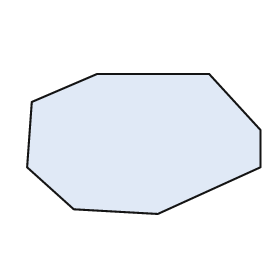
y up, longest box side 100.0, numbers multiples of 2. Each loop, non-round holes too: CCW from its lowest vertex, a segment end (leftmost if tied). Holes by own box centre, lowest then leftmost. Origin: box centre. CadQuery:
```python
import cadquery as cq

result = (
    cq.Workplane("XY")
    .moveTo(6.0, -30.0)
    .lineTo(50.0, -10.0)
    .lineTo(50.0, 6.0)
    .lineTo(28.0, 30.0)
    .lineTo(-20.0, 30.0)
    .lineTo(-48.0, 18.0)
    .lineTo(-50.0, -10.0)
    .lineTo(-30.0, -28.0)
    .close()
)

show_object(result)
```